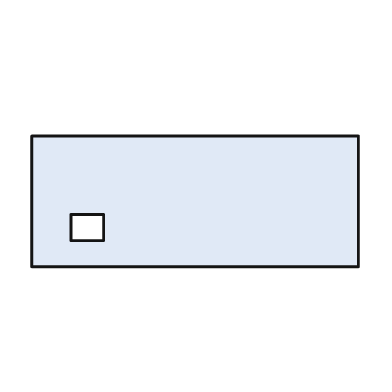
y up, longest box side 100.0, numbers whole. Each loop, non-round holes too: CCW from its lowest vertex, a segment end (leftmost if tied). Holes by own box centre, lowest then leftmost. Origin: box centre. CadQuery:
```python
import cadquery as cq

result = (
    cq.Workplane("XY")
    .moveTo(-50.0, -20.0)
    .lineTo(50.0, -20.0)
    .lineTo(50.0, 20.0)
    .lineTo(-50.0, 20.0)
    .close()
    .moveTo(-38.0, -12.0)
    .lineTo(-28.0, -12.0)
    .lineTo(-28.0, -4.0)
    .lineTo(-38.0, -4.0)
    .close()
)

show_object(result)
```